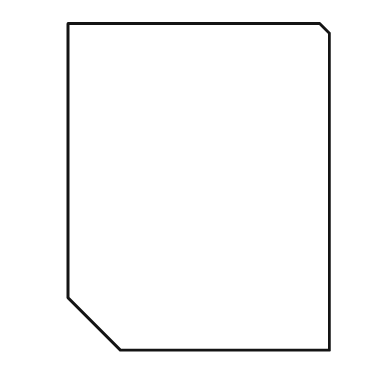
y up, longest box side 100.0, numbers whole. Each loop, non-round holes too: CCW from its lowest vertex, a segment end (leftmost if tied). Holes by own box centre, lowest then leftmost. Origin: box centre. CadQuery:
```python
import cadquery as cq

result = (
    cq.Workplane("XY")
    .moveTo(-24.0, -50.0)
    .lineTo(40.0, -50.0)
    .lineTo(40.0, 47.0)
    .lineTo(37.0, 50.0)
    .lineTo(-40.0, 50.0)
    .lineTo(-40.0, -34.0)
    .close()
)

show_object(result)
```